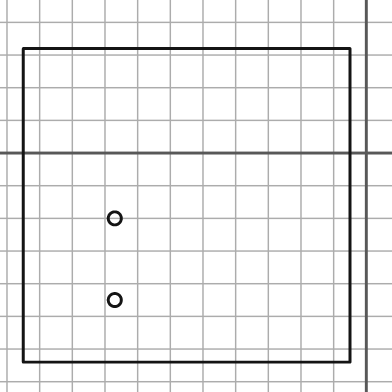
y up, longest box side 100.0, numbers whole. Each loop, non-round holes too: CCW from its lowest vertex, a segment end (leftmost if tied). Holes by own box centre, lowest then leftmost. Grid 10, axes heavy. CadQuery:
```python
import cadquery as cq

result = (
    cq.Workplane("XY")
    .moveTo(-105.0, -64.0)
    .lineTo(-5.0, -64.0)
    .lineTo(-5.0, 32.0)
    .lineTo(-105.0, 32.0)
    .close()
    .moveTo(-77.0, -45.0)
    .circle(2.0)
    .moveTo(-77.0, -20.0)
    .circle(2.0)
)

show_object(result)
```